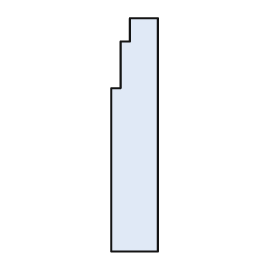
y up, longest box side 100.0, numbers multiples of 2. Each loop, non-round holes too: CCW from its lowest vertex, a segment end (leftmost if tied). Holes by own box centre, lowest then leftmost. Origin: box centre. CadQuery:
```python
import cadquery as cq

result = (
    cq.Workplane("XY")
    .moveTo(-10.0, -50.0)
    .lineTo(10.0, -50.0)
    .lineTo(10.0, 50.0)
    .lineTo(-2.0, 50.0)
    .lineTo(-2.0, 40.0)
    .lineTo(-6.0, 40.0)
    .lineTo(-6.0, 20.0)
    .lineTo(-10.0, 20.0)
    .close()
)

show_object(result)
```